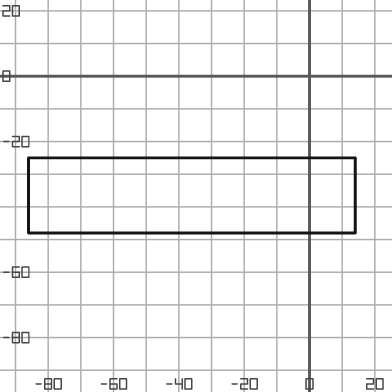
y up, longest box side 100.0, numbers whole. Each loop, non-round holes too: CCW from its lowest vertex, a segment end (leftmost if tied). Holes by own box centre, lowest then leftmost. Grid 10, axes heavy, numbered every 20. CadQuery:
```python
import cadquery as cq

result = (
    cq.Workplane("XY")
    .moveTo(-86.0, -48.0)
    .lineTo(14.0, -48.0)
    .lineTo(14.0, -25.0)
    .lineTo(-86.0, -25.0)
    .close()
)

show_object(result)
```